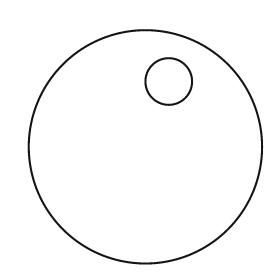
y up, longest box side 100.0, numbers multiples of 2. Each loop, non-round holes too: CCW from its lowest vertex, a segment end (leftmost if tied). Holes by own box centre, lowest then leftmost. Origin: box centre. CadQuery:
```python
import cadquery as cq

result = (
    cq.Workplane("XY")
    .moveTo(0.0, 0.0)
    .circle(50.0)
    .moveTo(10.0, 28.0)
    .circle(10.0)
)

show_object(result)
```